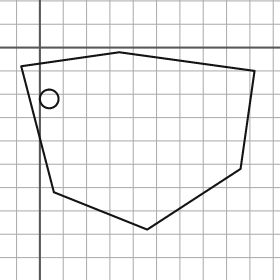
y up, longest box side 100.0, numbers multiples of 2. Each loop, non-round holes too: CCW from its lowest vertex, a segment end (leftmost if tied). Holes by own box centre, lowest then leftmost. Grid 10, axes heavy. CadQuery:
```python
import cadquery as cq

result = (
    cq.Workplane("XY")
    .moveTo(46.0, -78.0)
    .lineTo(86.0, -52.0)
    .lineTo(92.0, -10.0)
    .lineTo(34.0, -2.0)
    .lineTo(-8.0, -8.0)
    .lineTo(6.0, -62.0)
    .close()
    .moveTo(4.0, -22.0)
    .circle(4.0)
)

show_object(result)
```